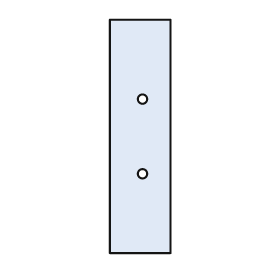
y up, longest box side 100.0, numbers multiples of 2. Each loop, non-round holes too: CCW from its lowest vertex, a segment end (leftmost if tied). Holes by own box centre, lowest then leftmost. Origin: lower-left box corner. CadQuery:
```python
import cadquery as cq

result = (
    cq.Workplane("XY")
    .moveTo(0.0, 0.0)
    .lineTo(26.0, 0.0)
    .lineTo(26.0, 100.0)
    .lineTo(0.0, 100.0)
    .close()
    .moveTo(14.0, 34.0)
    .circle(2.0)
    .moveTo(14.0, 66.0)
    .circle(2.0)
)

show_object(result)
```